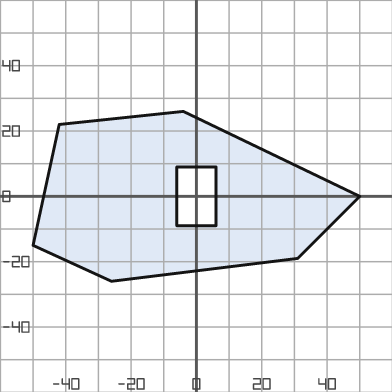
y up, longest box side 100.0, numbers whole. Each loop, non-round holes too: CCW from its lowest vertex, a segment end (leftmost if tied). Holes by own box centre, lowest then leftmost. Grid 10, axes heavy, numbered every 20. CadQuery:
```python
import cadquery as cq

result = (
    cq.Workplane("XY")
    .moveTo(-26.0, -26.0)
    .lineTo(31.0, -19.0)
    .lineTo(50.0, 0.0)
    .lineTo(-4.0, 26.0)
    .lineTo(-42.0, 22.0)
    .lineTo(-50.0, -15.0)
    .close()
    .moveTo(-6.0, -9.0)
    .lineTo(6.0, -9.0)
    .lineTo(6.0, 9.0)
    .lineTo(-6.0, 9.0)
    .close()
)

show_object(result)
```